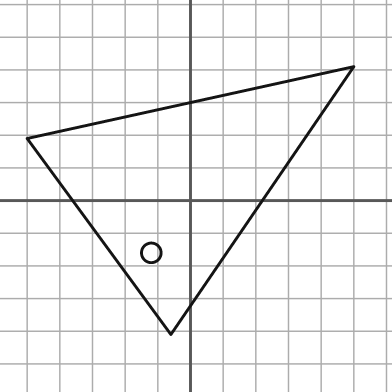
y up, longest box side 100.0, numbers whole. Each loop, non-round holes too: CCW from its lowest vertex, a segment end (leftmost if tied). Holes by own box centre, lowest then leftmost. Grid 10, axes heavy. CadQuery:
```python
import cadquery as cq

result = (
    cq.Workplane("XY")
    .moveTo(-6.0, -41.0)
    .lineTo(50.0, 41.0)
    .lineTo(-50.0, 19.0)
    .close()
    .moveTo(-12.0, -16.0)
    .circle(3.0)
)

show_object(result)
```